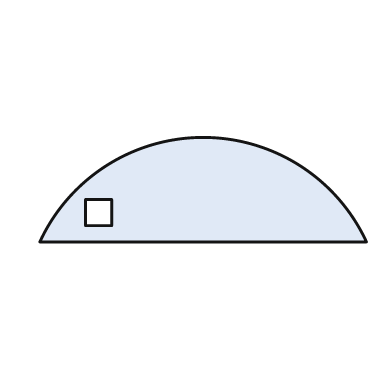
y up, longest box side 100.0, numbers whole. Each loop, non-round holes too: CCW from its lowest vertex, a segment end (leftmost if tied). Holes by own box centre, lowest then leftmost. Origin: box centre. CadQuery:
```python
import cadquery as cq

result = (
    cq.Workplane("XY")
    .moveTo(-50.0, -16.0)
    .lineTo(50.0, -16.0)
    .threePointArc((0.0, 16.0), (-50.0, -16.0))
    .close()
    .moveTo(-36.0, -11.0)
    .lineTo(-28.0, -11.0)
    .lineTo(-28.0, -3.0)
    .lineTo(-36.0, -3.0)
    .close()
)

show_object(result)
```